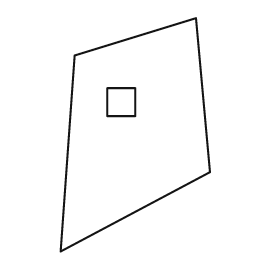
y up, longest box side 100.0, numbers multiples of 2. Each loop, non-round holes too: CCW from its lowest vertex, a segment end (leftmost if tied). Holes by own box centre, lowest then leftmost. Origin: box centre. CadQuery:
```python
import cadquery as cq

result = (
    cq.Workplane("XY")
    .moveTo(-32.0, -50.0)
    .lineTo(32.0, -16.0)
    .lineTo(26.0, 50.0)
    .lineTo(-26.0, 34.0)
    .close()
    .moveTo(-12.0, 8.0)
    .lineTo(0.0, 8.0)
    .lineTo(0.0, 20.0)
    .lineTo(-12.0, 20.0)
    .close()
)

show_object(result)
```